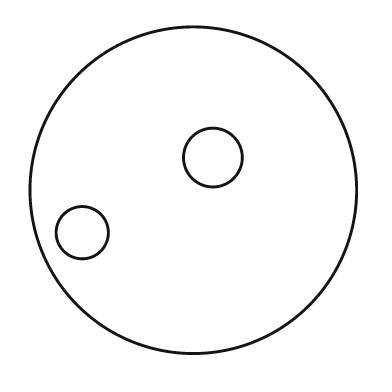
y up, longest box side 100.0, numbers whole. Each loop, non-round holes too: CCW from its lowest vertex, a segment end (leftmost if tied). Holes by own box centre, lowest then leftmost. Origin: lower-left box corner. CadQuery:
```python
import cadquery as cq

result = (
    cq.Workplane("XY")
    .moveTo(50.0, 50.0)
    .circle(50.0)
    .moveTo(16.0, 37.0)
    .circle(8.0)
    .moveTo(56.0, 60.0)
    .circle(9.0)
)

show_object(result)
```